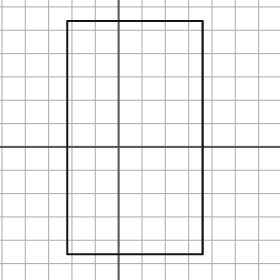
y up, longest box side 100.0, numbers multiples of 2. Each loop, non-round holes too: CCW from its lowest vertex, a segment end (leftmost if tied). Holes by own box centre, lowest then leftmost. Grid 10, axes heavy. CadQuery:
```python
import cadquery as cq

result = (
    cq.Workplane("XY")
    .moveTo(-22.0, -46.0)
    .lineTo(36.0, -46.0)
    .lineTo(36.0, 54.0)
    .lineTo(-22.0, 54.0)
    .close()
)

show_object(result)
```